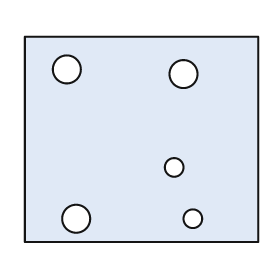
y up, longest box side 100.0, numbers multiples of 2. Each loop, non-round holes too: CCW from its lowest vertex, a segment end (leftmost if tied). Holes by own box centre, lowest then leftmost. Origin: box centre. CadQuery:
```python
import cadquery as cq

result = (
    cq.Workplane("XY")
    .moveTo(-50.0, -44.0)
    .lineTo(50.0, -44.0)
    .lineTo(50.0, 44.0)
    .lineTo(-50.0, 44.0)
    .close()
    .moveTo(-28.0, -34.0)
    .circle(6.0)
    .moveTo(22.0, -34.0)
    .circle(4.0)
    .moveTo(14.0, -12.0)
    .circle(4.0)
    .moveTo(18.0, 28.0)
    .circle(6.0)
    .moveTo(-32.0, 30.0)
    .circle(6.0)
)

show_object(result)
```